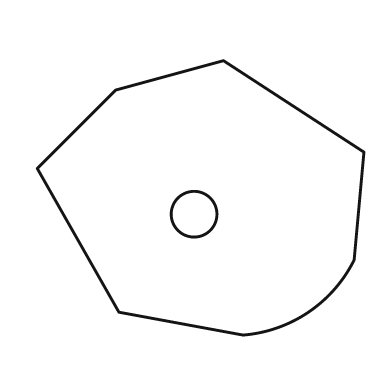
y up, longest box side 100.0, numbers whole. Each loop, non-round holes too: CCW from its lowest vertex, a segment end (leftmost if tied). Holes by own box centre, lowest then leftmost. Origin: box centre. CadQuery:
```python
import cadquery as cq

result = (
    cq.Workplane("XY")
    .moveTo(13.0, -42.0)
    .threePointArc((33.0, -35.0), (47.0, -19.0))
    .lineTo(50.0, 14.0)
    .lineTo(7.0, 42.0)
    .lineTo(-26.0, 33.0)
    .lineTo(-50.0, 9.0)
    .lineTo(-25.0, -35.0)
    .close()
    .moveTo(-2.0, -5.0)
    .circle(7.0)
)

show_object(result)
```